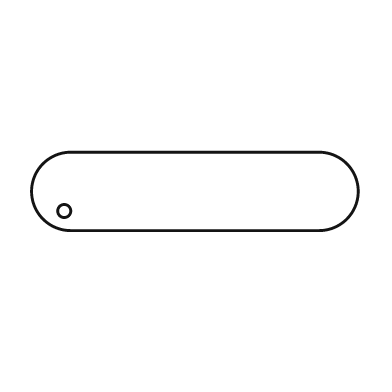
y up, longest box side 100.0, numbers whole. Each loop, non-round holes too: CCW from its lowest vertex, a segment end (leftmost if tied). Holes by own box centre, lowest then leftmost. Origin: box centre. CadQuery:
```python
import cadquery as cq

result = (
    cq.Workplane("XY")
    .moveTo(-38.0, -12.0)
    .lineTo(38.0, -12.0)
    .threePointArc((50.0, 0.0), (38.0, 12.0))
    .lineTo(-38.0, 12.0)
    .threePointArc((-50.0, 0.0), (-38.0, -12.0))
    .close()
    .moveTo(-40.0, -6.0)
    .circle(2.0)
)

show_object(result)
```